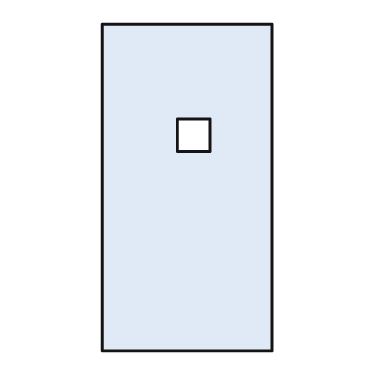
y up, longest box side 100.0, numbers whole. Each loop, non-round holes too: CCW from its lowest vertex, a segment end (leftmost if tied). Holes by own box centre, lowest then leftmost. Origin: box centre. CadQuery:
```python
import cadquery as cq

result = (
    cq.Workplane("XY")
    .moveTo(-26.0, -50.0)
    .lineTo(26.0, -50.0)
    .lineTo(26.0, 50.0)
    .lineTo(-26.0, 50.0)
    .close()
    .moveTo(-3.0, 11.0)
    .lineTo(7.0, 11.0)
    .lineTo(7.0, 21.0)
    .lineTo(-3.0, 21.0)
    .close()
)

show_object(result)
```